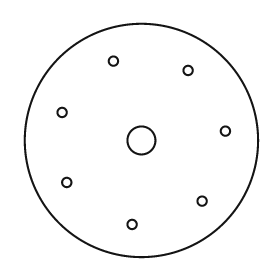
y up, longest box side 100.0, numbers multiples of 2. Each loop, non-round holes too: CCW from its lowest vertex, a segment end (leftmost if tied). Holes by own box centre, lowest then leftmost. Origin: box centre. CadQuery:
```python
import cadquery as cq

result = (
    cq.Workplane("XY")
    .moveTo(0.0, 0.0)
    .circle(50.0)
    .moveTo(-4.0, -36.0)
    .circle(2.0)
    .moveTo(26.0, -26.0)
    .circle(2.0)
    .moveTo(-32.0, -18.0)
    .circle(2.0)
    .moveTo(0.0, 0.0)
    .circle(6.0)
    .moveTo(36.0, 4.0)
    .circle(2.0)
    .moveTo(-34.0, 12.0)
    .circle(2.0)
    .moveTo(20.0, 30.0)
    .circle(2.0)
    .moveTo(-12.0, 34.0)
    .circle(2.0)
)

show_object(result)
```